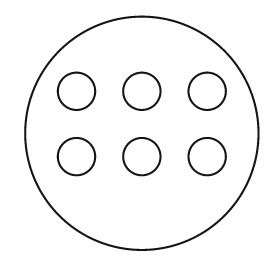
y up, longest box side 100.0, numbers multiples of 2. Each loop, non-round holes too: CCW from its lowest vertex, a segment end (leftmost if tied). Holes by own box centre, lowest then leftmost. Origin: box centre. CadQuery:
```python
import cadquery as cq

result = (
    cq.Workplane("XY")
    .moveTo(0.0, 0.0)
    .circle(50.0)
    .moveTo(-28.0, -10.0)
    .circle(8.0)
    .moveTo(0.0, -10.0)
    .circle(8.0)
    .moveTo(28.0, -10.0)
    .circle(8.0)
    .moveTo(-28.0, 18.0)
    .circle(8.0)
    .moveTo(0.0, 18.0)
    .circle(8.0)
    .moveTo(28.0, 18.0)
    .circle(8.0)
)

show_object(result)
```